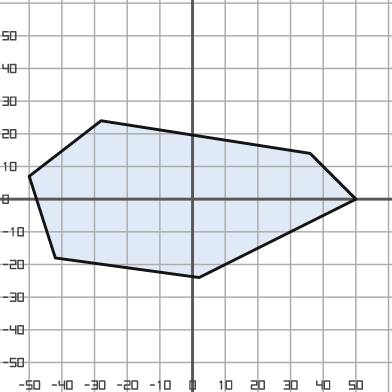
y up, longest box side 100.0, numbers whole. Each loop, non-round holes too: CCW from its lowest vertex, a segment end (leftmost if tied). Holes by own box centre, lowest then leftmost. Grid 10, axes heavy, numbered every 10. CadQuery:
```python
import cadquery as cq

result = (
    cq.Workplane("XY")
    .moveTo(2.0, -24.0)
    .lineTo(50.0, 0.0)
    .lineTo(36.0, 14.0)
    .lineTo(-28.0, 24.0)
    .lineTo(-50.0, 7.0)
    .lineTo(-42.0, -18.0)
    .close()
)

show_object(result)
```